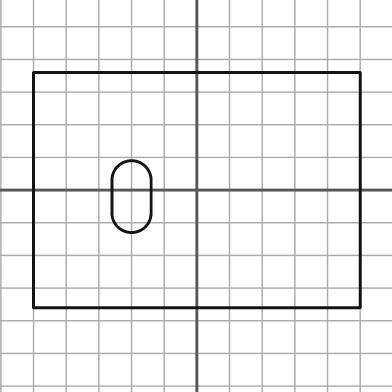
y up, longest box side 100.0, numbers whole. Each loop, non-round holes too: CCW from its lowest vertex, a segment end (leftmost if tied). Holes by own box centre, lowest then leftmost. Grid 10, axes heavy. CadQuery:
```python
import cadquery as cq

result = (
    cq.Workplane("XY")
    .moveTo(-50.0, -36.0)
    .lineTo(50.0, -36.0)
    .lineTo(50.0, 36.0)
    .lineTo(-50.0, 36.0)
    .close()
    .moveTo(-26.0, -7.0)
    .threePointArc((-20.0, -13.0), (-14.0, -7.0))
    .lineTo(-14.0, 3.0)
    .threePointArc((-20.0, 9.0), (-26.0, 3.0))
    .close()
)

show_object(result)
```